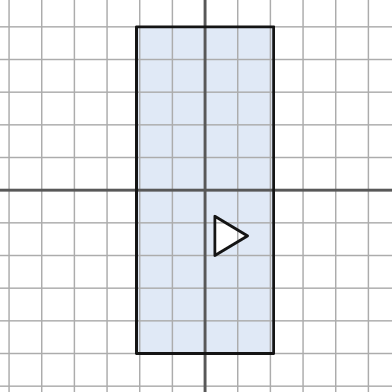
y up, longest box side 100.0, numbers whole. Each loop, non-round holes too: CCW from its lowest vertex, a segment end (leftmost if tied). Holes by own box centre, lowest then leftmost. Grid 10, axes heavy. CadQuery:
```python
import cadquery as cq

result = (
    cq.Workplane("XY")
    .moveTo(-21.0, -50.0)
    .lineTo(21.0, -50.0)
    .lineTo(21.0, 50.0)
    .lineTo(-21.0, 50.0)
    .close()
    .moveTo(3.0, -20.0)
    .lineTo(13.0, -14.0)
    .lineTo(3.0, -8.0)
    .close()
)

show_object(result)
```